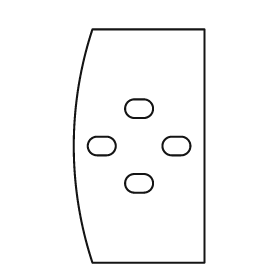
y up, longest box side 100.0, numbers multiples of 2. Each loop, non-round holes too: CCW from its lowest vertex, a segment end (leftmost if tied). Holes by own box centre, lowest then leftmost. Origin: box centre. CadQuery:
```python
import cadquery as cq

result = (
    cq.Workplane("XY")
    .moveTo(-20.0, -50.0)
    .lineTo(28.0, -50.0)
    .lineTo(28.0, 50.0)
    .lineTo(-20.0, 50.0)
    .threePointArc((-28.0, 0.0), (-20.0, -50.0))
    .close()
    .moveTo(-2.0, -20.0)
    .lineTo(2.0, -20.0)
    .threePointArc((6.0, -16.0), (2.0, -12.0))
    .lineTo(-2.0, -12.0)
    .threePointArc((-6.0, -16.0), (-2.0, -20.0))
    .close()
    .moveTo(-18.0, -4.0)
    .lineTo(-14.0, -4.0)
    .threePointArc((-10.0, 0.0), (-14.0, 4.0))
    .lineTo(-18.0, 4.0)
    .threePointArc((-22.0, 0.0), (-18.0, -4.0))
    .close()
    .moveTo(14.0, -4.0)
    .lineTo(18.0, -4.0)
    .threePointArc((22.0, 0.0), (18.0, 4.0))
    .lineTo(14.0, 4.0)
    .threePointArc((10.0, 0.0), (14.0, -4.0))
    .close()
    .moveTo(-2.0, 12.0)
    .lineTo(2.0, 12.0)
    .threePointArc((6.0, 16.0), (2.0, 20.0))
    .lineTo(-2.0, 20.0)
    .threePointArc((-6.0, 16.0), (-2.0, 12.0))
    .close()
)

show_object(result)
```